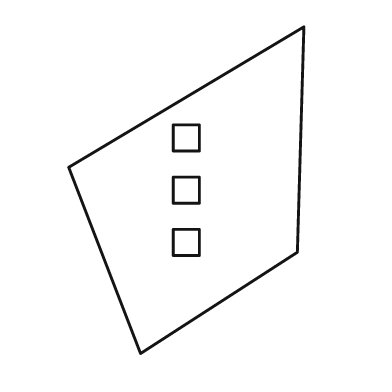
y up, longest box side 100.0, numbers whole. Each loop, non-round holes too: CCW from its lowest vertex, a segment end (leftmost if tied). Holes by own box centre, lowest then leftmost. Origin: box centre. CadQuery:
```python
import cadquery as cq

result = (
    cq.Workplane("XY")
    .moveTo(-14.0, -50.0)
    .lineTo(34.0, -19.0)
    .lineTo(36.0, 50.0)
    .lineTo(-36.0, 7.0)
    .close()
    .moveTo(-4.0, -20.0)
    .lineTo(4.0, -20.0)
    .lineTo(4.0, -12.0)
    .lineTo(-4.0, -12.0)
    .close()
    .moveTo(-4.0, -4.0)
    .lineTo(4.0, -4.0)
    .lineTo(4.0, 4.0)
    .lineTo(-4.0, 4.0)
    .close()
    .moveTo(-4.0, 12.0)
    .lineTo(4.0, 12.0)
    .lineTo(4.0, 20.0)
    .lineTo(-4.0, 20.0)
    .close()
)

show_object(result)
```